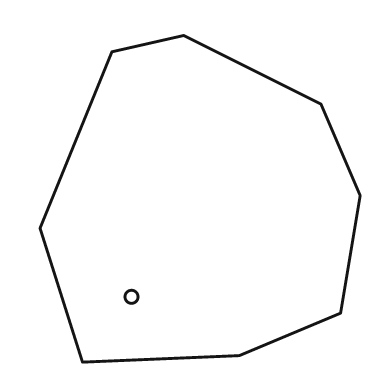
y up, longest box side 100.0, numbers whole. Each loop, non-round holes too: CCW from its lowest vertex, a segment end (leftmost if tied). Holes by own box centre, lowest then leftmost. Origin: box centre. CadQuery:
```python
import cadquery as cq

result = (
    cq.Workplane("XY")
    .moveTo(-36.0, -50.0)
    .lineTo(12.0, -48.0)
    .lineTo(43.0, -35.0)
    .lineTo(49.0, 1.0)
    .lineTo(37.0, 29.0)
    .lineTo(-5.0, 50.0)
    .lineTo(-27.0, 45.0)
    .lineTo(-49.0, -9.0)
    .close()
    .moveTo(-21.0, -30.0)
    .circle(2.0)
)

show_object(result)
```